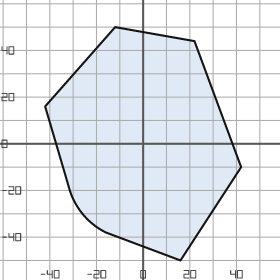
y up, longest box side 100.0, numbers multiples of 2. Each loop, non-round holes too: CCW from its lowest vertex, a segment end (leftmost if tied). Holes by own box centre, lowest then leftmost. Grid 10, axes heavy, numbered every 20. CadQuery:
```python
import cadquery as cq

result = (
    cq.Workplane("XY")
    .moveTo(16.0, -50.0)
    .lineTo(42.0, -10.0)
    .lineTo(22.0, 44.0)
    .lineTo(-12.0, 50.0)
    .lineTo(-42.0, 16.0)
    .lineTo(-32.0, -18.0)
    .threePointArc((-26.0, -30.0), (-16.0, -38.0))
    .close()
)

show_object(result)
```